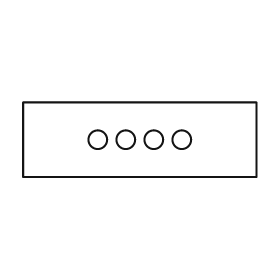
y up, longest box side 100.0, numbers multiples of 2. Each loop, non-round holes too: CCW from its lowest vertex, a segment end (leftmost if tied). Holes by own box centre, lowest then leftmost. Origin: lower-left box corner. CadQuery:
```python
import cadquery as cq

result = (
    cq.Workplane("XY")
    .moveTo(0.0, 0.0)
    .lineTo(100.0, 0.0)
    .lineTo(100.0, 32.0)
    .lineTo(0.0, 32.0)
    .close()
    .moveTo(32.0, 16.0)
    .circle(4.0)
    .moveTo(44.0, 16.0)
    .circle(4.0)
    .moveTo(56.0, 16.0)
    .circle(4.0)
    .moveTo(68.0, 16.0)
    .circle(4.0)
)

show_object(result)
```